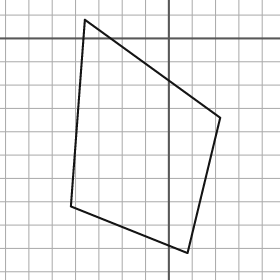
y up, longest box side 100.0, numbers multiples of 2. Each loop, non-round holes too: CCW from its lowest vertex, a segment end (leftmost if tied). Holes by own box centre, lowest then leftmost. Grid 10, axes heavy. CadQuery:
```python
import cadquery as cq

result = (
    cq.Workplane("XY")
    .moveTo(8.0, -92.0)
    .lineTo(22.0, -34.0)
    .lineTo(-36.0, 8.0)
    .lineTo(-42.0, -72.0)
    .close()
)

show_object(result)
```